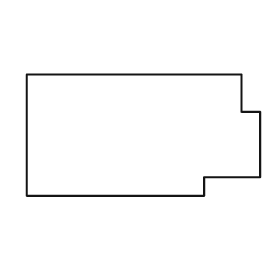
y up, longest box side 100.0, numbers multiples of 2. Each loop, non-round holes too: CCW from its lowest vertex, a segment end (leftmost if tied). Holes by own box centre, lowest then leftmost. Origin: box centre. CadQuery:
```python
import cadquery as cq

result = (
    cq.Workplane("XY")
    .moveTo(-50.0, -26.0)
    .lineTo(26.0, -26.0)
    .lineTo(26.0, -18.0)
    .lineTo(50.0, -18.0)
    .lineTo(50.0, 10.0)
    .lineTo(42.0, 10.0)
    .lineTo(42.0, 26.0)
    .lineTo(-50.0, 26.0)
    .close()
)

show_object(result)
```